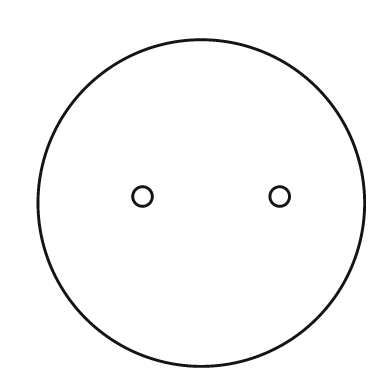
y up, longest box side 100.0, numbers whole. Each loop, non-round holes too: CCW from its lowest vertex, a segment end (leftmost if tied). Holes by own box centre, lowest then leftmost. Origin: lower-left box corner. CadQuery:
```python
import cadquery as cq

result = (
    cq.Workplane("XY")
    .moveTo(50.0, 50.0)
    .circle(50.0)
    .moveTo(32.0, 52.0)
    .circle(3.0)
    .moveTo(74.0, 52.0)
    .circle(3.0)
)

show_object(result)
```